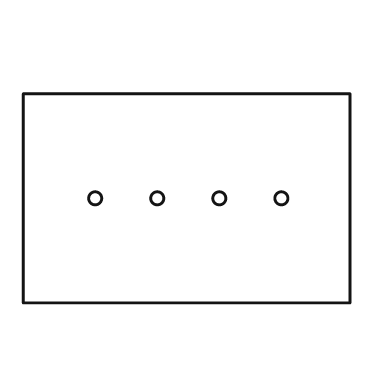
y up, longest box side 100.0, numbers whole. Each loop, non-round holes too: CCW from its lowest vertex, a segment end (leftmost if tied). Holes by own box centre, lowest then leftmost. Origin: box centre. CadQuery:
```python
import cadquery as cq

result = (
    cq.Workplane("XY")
    .moveTo(-50.0, -32.0)
    .lineTo(50.0, -32.0)
    .lineTo(50.0, 32.0)
    .lineTo(-50.0, 32.0)
    .close()
    .moveTo(-28.0, 0.0)
    .circle(2.0)
    .moveTo(-9.0, 0.0)
    .circle(2.0)
    .moveTo(10.0, 0.0)
    .circle(2.0)
    .moveTo(29.0, 0.0)
    .circle(2.0)
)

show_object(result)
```